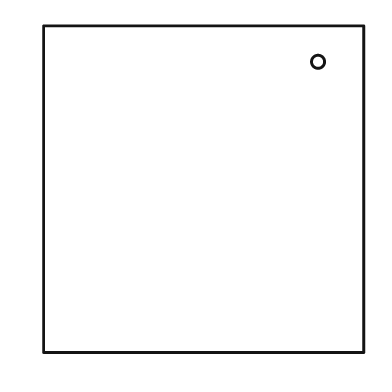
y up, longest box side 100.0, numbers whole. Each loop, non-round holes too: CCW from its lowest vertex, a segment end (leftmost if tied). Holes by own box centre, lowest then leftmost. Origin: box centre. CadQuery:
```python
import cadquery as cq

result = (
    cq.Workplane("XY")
    .moveTo(-49.0, -50.0)
    .lineTo(49.0, -50.0)
    .lineTo(49.0, 50.0)
    .lineTo(-49.0, 50.0)
    .close()
    .moveTo(35.0, 39.0)
    .circle(2.0)
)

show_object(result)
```